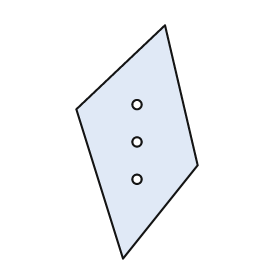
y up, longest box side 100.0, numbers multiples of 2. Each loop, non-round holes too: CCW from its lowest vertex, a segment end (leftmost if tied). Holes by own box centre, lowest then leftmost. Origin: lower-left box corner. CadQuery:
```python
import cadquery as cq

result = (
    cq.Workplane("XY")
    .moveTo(20.0, 0.0)
    .lineTo(52.0, 40.0)
    .lineTo(38.0, 100.0)
    .lineTo(0.0, 64.0)
    .close()
    .moveTo(26.0, 34.0)
    .circle(2.0)
    .moveTo(26.0, 50.0)
    .circle(2.0)
    .moveTo(26.0, 66.0)
    .circle(2.0)
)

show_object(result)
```